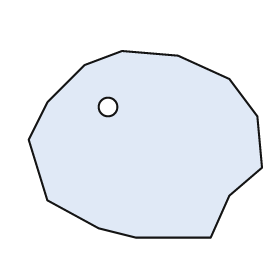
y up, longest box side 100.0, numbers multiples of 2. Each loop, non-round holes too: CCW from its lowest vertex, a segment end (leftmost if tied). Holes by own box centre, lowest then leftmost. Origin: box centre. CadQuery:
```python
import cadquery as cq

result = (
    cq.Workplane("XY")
    .moveTo(-4.0, -40.0)
    .lineTo(28.0, -40.0)
    .lineTo(36.0, -22.0)
    .lineTo(50.0, -10.0)
    .lineTo(48.0, 12.0)
    .lineTo(36.0, 28.0)
    .lineTo(14.0, 38.0)
    .lineTo(-10.0, 40.0)
    .lineTo(-26.0, 34.0)
    .lineTo(-42.0, 18.0)
    .lineTo(-50.0, 2.0)
    .lineTo(-42.0, -24.0)
    .lineTo(-20.0, -36.0)
    .close()
    .moveTo(-16.0, 16.0)
    .circle(4.0)
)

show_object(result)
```